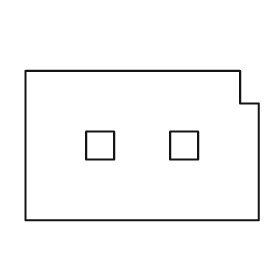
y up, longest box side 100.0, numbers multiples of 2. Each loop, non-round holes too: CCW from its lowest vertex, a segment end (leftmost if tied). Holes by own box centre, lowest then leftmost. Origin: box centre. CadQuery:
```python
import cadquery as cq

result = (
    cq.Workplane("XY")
    .moveTo(-50.0, -32.0)
    .lineTo(50.0, -32.0)
    .lineTo(50.0, 18.0)
    .lineTo(42.0, 18.0)
    .lineTo(42.0, 32.0)
    .lineTo(-50.0, 32.0)
    .close()
    .moveTo(-24.0, -6.0)
    .lineTo(-12.0, -6.0)
    .lineTo(-12.0, 6.0)
    .lineTo(-24.0, 6.0)
    .close()
    .moveTo(12.0, -6.0)
    .lineTo(24.0, -6.0)
    .lineTo(24.0, 6.0)
    .lineTo(12.0, 6.0)
    .close()
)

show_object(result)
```